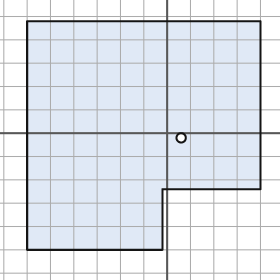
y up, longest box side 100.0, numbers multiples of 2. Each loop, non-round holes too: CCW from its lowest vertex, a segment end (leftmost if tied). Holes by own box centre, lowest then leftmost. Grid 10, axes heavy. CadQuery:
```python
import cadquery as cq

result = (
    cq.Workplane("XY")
    .moveTo(-60.0, -50.0)
    .lineTo(-2.0, -50.0)
    .lineTo(-2.0, -24.0)
    .lineTo(40.0, -24.0)
    .lineTo(40.0, 48.0)
    .lineTo(-60.0, 48.0)
    .close()
    .moveTo(6.0, -2.0)
    .circle(2.0)
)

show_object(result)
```